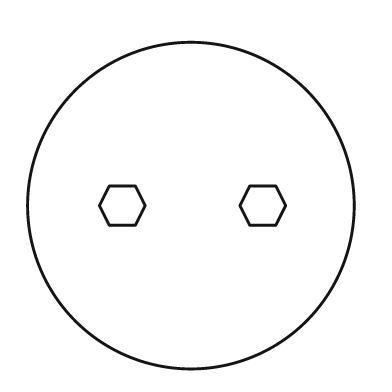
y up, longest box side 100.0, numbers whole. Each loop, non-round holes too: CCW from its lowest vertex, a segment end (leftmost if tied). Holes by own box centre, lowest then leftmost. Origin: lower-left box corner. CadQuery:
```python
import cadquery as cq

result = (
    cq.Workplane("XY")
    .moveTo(50.0, 50.0)
    .circle(50.0)
    .moveTo(25.0, 44.0)
    .lineTo(33.0, 44.0)
    .lineTo(36.0, 50.0)
    .lineTo(33.0, 56.0)
    .lineTo(25.0, 56.0)
    .lineTo(22.0, 50.0)
    .close()
    .moveTo(68.0, 44.0)
    .lineTo(76.0, 44.0)
    .lineTo(79.0, 50.0)
    .lineTo(76.0, 56.0)
    .lineTo(68.0, 56.0)
    .lineTo(65.0, 50.0)
    .close()
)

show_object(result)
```